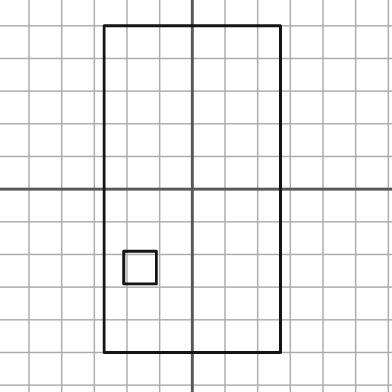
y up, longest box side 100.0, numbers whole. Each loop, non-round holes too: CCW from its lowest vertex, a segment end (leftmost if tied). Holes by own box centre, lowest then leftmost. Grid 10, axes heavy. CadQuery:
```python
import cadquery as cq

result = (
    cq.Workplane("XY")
    .moveTo(-27.0, -50.0)
    .lineTo(27.0, -50.0)
    .lineTo(27.0, 50.0)
    .lineTo(-27.0, 50.0)
    .close()
    .moveTo(-21.0, -29.0)
    .lineTo(-11.0, -29.0)
    .lineTo(-11.0, -19.0)
    .lineTo(-21.0, -19.0)
    .close()
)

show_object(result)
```